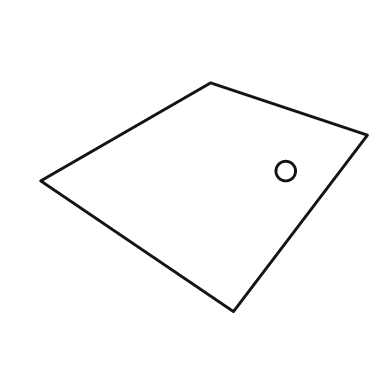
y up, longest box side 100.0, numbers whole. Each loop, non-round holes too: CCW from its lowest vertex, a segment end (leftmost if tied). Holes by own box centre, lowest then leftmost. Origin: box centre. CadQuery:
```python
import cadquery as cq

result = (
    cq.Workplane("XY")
    .moveTo(9.0, -35.0)
    .lineTo(50.0, 19.0)
    .lineTo(2.0, 35.0)
    .lineTo(-50.0, 5.0)
    .close()
    .moveTo(25.0, 8.0)
    .circle(3.0)
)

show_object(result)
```